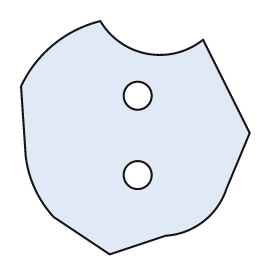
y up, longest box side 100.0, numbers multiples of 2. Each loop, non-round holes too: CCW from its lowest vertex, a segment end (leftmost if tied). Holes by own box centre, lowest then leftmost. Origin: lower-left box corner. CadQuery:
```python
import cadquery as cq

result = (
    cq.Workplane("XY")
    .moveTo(38.0, 0.0)
    .lineTo(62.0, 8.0)
    .threePointArc((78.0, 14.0), (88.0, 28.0))
    .lineTo(98.0, 52.0)
    .lineTo(78.0, 92.0)
    .threePointArc((54.0, 86.0), (34.0, 100.0))
    .threePointArc((14.0, 90.0), (0.0, 72.0))
    .lineTo(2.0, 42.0)
    .threePointArc((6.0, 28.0), (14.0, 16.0))
    .close()
    .moveTo(50.0, 34.0)
    .circle(6.0)
    .moveTo(50.0, 68.0)
    .circle(6.0)
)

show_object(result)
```